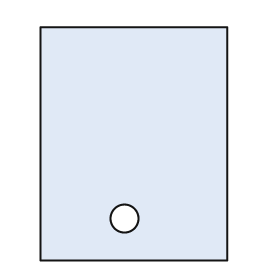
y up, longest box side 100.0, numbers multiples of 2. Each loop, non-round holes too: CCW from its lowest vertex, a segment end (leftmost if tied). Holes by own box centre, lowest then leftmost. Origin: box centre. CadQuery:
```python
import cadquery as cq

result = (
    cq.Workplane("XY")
    .moveTo(-40.0, -50.0)
    .lineTo(40.0, -50.0)
    .lineTo(40.0, 50.0)
    .lineTo(-40.0, 50.0)
    .close()
    .moveTo(-4.0, -32.0)
    .circle(6.0)
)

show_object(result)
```